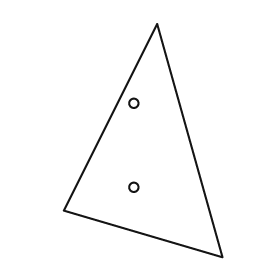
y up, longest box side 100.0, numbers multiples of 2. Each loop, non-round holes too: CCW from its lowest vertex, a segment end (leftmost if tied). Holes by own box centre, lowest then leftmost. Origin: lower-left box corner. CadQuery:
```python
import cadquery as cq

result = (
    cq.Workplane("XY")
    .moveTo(68.0, 0.0)
    .lineTo(40.0, 100.0)
    .lineTo(0.0, 20.0)
    .close()
    .moveTo(30.0, 30.0)
    .circle(2.0)
    .moveTo(30.0, 66.0)
    .circle(2.0)
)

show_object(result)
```